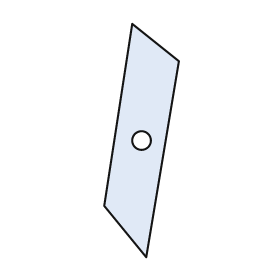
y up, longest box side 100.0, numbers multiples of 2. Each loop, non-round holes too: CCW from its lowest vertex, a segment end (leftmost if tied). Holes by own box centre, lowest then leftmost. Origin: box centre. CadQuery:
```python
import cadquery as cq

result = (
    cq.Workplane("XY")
    .moveTo(2.0, -50.0)
    .lineTo(16.0, 34.0)
    .lineTo(-4.0, 50.0)
    .lineTo(-16.0, -28.0)
    .close()
    .moveTo(0.0, 0.0)
    .circle(4.0)
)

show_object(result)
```